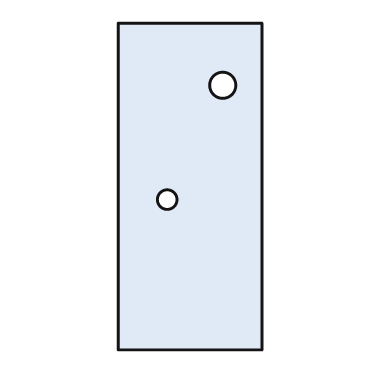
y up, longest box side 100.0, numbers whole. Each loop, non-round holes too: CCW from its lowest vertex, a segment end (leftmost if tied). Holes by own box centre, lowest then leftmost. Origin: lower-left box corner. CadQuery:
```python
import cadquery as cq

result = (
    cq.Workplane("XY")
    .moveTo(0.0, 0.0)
    .lineTo(44.0, 0.0)
    .lineTo(44.0, 100.0)
    .lineTo(0.0, 100.0)
    .close()
    .moveTo(15.0, 46.0)
    .circle(3.0)
    .moveTo(32.0, 81.0)
    .circle(4.0)
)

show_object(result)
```